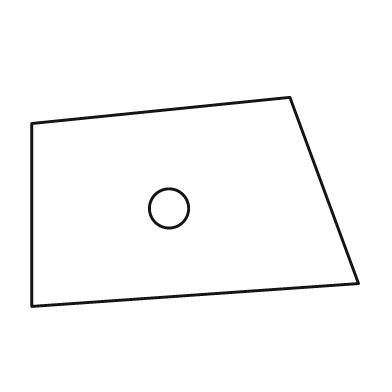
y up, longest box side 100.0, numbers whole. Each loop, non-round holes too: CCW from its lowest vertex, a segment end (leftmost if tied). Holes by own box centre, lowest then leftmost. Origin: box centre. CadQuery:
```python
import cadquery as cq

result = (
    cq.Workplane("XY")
    .moveTo(-50.0, -32.0)
    .lineTo(50.0, -25.0)
    .lineTo(29.0, 32.0)
    .lineTo(-50.0, 24.0)
    .close()
    .moveTo(-8.0, -2.0)
    .circle(6.0)
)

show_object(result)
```